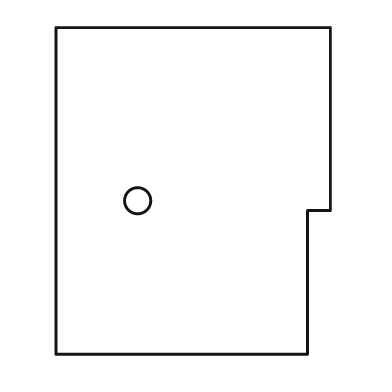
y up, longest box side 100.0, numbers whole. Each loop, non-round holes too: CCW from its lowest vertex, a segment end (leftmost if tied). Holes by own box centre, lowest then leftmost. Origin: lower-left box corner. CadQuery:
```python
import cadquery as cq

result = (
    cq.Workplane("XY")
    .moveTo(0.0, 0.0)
    .lineTo(77.0, 0.0)
    .lineTo(77.0, 44.0)
    .lineTo(84.0, 44.0)
    .lineTo(84.0, 100.0)
    .lineTo(0.0, 100.0)
    .close()
    .moveTo(25.0, 47.0)
    .circle(4.0)
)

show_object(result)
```